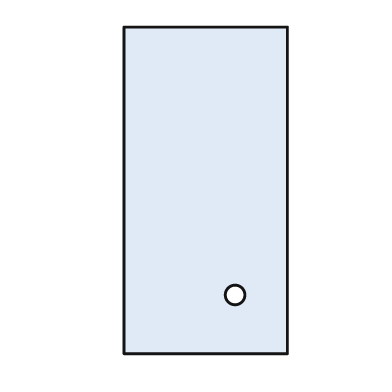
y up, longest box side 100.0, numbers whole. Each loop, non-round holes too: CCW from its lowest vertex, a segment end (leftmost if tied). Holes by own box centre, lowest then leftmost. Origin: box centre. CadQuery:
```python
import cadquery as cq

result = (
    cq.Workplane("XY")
    .moveTo(-25.0, -50.0)
    .lineTo(25.0, -50.0)
    .lineTo(25.0, 50.0)
    .lineTo(-25.0, 50.0)
    .close()
    .moveTo(9.0, -32.0)
    .circle(3.0)
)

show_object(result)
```